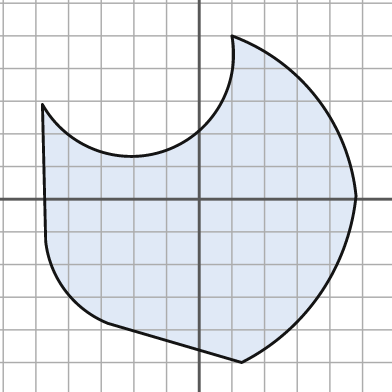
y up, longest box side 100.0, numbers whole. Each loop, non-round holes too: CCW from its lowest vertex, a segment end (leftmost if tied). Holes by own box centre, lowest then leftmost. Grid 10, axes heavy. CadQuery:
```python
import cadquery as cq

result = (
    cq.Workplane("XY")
    .moveTo(13.0, -50.0)
    .threePointArc((37.0, -29.0), (48.0, 1.0))
    .threePointArc((36.0, 31.0), (10.0, 50.0))
    .threePointArc((-10.0, 15.0), (-48.0, 29.0))
    .lineTo(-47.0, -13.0)
    .threePointArc((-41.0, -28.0), (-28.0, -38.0))
    .close()
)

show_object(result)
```